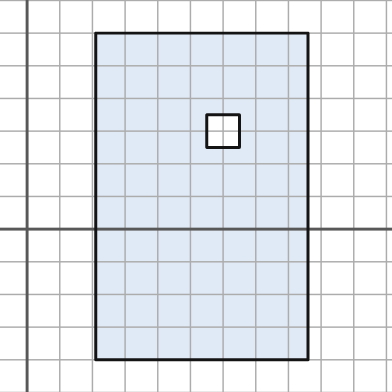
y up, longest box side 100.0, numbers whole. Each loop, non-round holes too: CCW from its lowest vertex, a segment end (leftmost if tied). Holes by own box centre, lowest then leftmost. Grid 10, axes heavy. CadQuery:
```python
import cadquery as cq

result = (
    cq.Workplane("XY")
    .moveTo(21.0, -40.0)
    .lineTo(86.0, -40.0)
    .lineTo(86.0, 60.0)
    .lineTo(21.0, 60.0)
    .close()
    .moveTo(55.0, 25.0)
    .lineTo(65.0, 25.0)
    .lineTo(65.0, 35.0)
    .lineTo(55.0, 35.0)
    .close()
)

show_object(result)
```